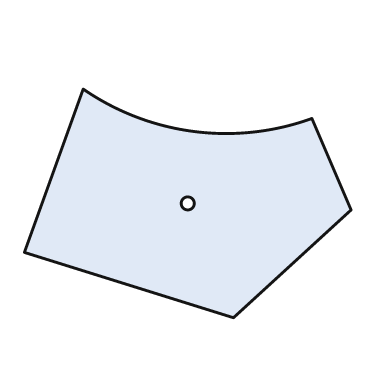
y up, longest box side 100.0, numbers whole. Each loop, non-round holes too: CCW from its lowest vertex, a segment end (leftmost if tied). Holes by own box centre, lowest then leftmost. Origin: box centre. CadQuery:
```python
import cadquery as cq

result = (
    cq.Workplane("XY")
    .moveTo(14.0, -35.0)
    .lineTo(50.0, -2.0)
    .lineTo(38.0, 26.0)
    .threePointArc((2.0, 22.0), (-32.0, 35.0))
    .lineTo(-50.0, -15.0)
    .close()
    .moveTo(0.0, 0.0)
    .circle(2.0)
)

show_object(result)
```